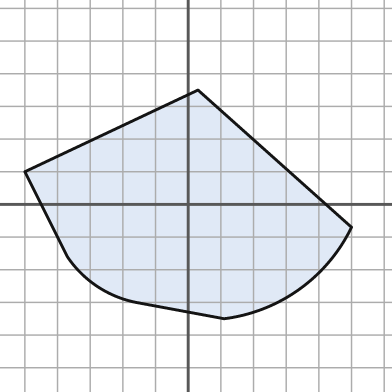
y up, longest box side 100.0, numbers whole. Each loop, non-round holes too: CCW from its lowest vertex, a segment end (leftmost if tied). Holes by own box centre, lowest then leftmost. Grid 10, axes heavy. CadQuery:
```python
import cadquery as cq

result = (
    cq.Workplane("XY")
    .moveTo(11.0, -35.0)
    .threePointArc((34.0, -26.0), (50.0, -7.0))
    .lineTo(3.0, 35.0)
    .lineTo(-50.0, 10.0)
    .lineTo(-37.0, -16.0)
    .threePointArc((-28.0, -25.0), (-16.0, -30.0))
    .close()
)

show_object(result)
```